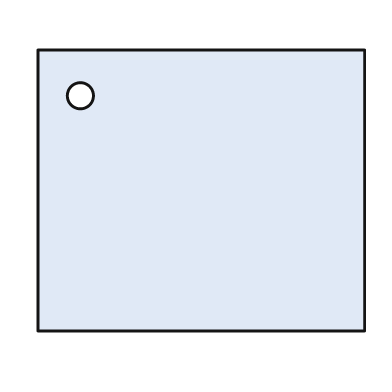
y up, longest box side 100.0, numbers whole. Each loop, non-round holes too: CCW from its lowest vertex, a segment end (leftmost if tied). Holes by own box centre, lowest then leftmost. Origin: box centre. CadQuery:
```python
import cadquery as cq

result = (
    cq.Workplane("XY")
    .moveTo(-50.0, -43.0)
    .lineTo(50.0, -43.0)
    .lineTo(50.0, 43.0)
    .lineTo(-50.0, 43.0)
    .close()
    .moveTo(-37.0, 29.0)
    .circle(4.0)
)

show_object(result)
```